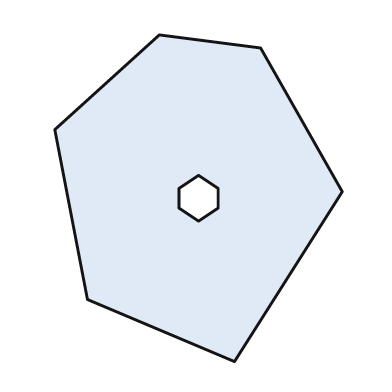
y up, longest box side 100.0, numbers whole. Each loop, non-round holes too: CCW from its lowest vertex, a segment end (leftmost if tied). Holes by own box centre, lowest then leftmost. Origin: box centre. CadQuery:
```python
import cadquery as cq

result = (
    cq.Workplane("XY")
    .moveTo(11.0, -50.0)
    .lineTo(44.0, 2.0)
    .lineTo(19.0, 46.0)
    .lineTo(-12.0, 50.0)
    .lineTo(-44.0, 21.0)
    .lineTo(-34.0, -31.0)
    .close()
    .moveTo(0.0, -7.0)
    .lineTo(6.0, -3.0)
    .lineTo(6.0, 3.0)
    .lineTo(0.0, 7.0)
    .lineTo(-6.0, 3.0)
    .lineTo(-6.0, -3.0)
    .close()
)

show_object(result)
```